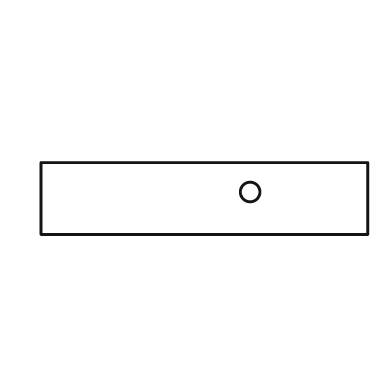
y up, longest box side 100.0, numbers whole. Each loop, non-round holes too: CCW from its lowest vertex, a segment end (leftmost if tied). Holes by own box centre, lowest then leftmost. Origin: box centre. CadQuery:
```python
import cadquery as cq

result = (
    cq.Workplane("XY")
    .moveTo(-50.0, -11.0)
    .lineTo(50.0, -11.0)
    .lineTo(50.0, 11.0)
    .lineTo(-50.0, 11.0)
    .close()
    .moveTo(14.0, 2.0)
    .circle(3.0)
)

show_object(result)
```